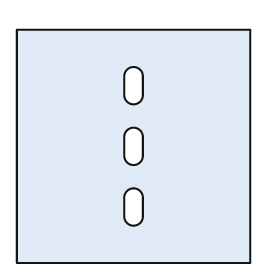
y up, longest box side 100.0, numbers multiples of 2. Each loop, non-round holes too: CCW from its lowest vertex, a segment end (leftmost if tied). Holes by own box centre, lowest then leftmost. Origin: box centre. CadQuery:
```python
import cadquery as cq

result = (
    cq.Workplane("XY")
    .moveTo(-50.0, -50.0)
    .lineTo(50.0, -50.0)
    .lineTo(50.0, 50.0)
    .lineTo(-50.0, 50.0)
    .close()
    .moveTo(-4.0, -30.0)
    .threePointArc((0.0, -34.0), (4.0, -30.0))
    .lineTo(4.0, -22.0)
    .threePointArc((0.0, -18.0), (-4.0, -22.0))
    .close()
    .moveTo(-4.0, -4.0)
    .threePointArc((0.0, -8.0), (4.0, -4.0))
    .lineTo(4.0, 4.0)
    .threePointArc((0.0, 8.0), (-4.0, 4.0))
    .close()
    .moveTo(-4.0, 22.0)
    .threePointArc((0.0, 18.0), (4.0, 22.0))
    .lineTo(4.0, 30.0)
    .threePointArc((0.0, 34.0), (-4.0, 30.0))
    .close()
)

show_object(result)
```